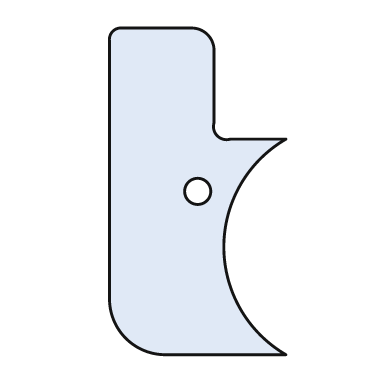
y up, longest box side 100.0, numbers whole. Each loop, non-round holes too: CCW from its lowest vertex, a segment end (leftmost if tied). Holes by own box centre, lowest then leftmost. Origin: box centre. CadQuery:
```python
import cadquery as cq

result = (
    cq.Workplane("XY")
    .moveTo(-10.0, -50.0)
    .lineTo(27.0, -50.0)
    .threePointArc((8.0, -17.0), (27.0, 16.0))
    .lineTo(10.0, 16.0)
    .threePointArc((6.0, 17.0), (5.0, 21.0))
    .lineTo(5.0, 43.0)
    .threePointArc((3.0, 48.0), (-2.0, 50.0))
    .lineTo(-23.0, 50.0)
    .threePointArc((-26.0, 49.0), (-27.0, 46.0))
    .lineTo(-27.0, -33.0)
    .threePointArc((-22.0, -45.0), (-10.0, -50.0))
    .close()
    .moveTo(0.0, 0.0)
    .circle(4.0)
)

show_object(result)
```